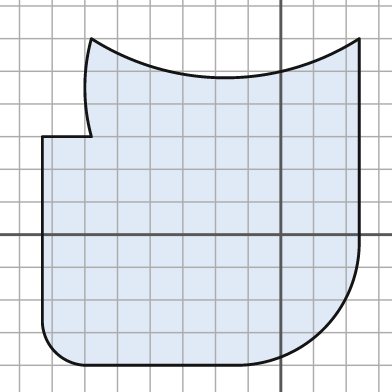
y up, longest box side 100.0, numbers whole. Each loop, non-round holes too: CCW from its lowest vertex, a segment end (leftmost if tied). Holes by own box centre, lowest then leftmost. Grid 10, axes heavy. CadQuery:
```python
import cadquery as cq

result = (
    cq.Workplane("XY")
    .moveTo(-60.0, -40.0)
    .lineTo(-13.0, -40.0)
    .threePointArc((13.0, -29.0), (24.0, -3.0))
    .lineTo(24.0, 60.0)
    .threePointArc((-17.0, 48.0), (-58.0, 60.0))
    .threePointArc((-60.0, 45.0), (-58.0, 30.0))
    .lineTo(-73.0, 30.0)
    .lineTo(-73.0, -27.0)
    .threePointArc((-69.0, -36.0), (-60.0, -40.0))
    .close()
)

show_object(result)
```